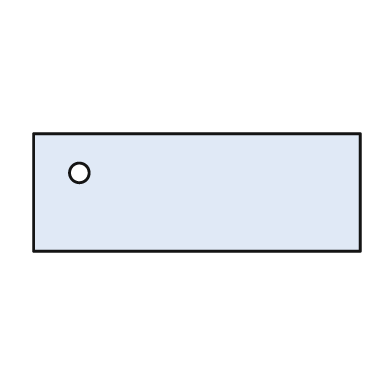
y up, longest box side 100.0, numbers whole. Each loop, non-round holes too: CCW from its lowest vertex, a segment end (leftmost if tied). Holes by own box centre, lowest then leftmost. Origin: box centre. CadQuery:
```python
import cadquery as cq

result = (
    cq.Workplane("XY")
    .moveTo(-50.0, -18.0)
    .lineTo(50.0, -18.0)
    .lineTo(50.0, 18.0)
    .lineTo(-50.0, 18.0)
    .close()
    .moveTo(-36.0, 6.0)
    .circle(3.0)
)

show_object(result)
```